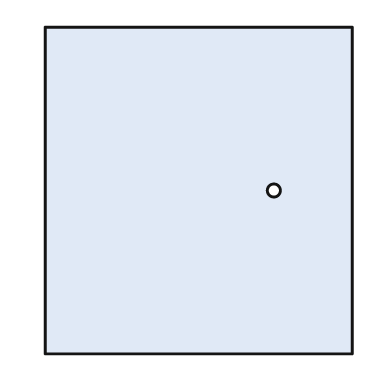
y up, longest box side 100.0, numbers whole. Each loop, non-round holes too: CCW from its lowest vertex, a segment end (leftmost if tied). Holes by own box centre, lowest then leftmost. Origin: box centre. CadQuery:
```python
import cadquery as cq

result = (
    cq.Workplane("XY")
    .moveTo(-47.0, -50.0)
    .lineTo(47.0, -50.0)
    .lineTo(47.0, 50.0)
    .lineTo(-47.0, 50.0)
    .close()
    .moveTo(23.0, 0.0)
    .circle(2.0)
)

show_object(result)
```